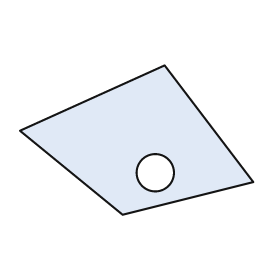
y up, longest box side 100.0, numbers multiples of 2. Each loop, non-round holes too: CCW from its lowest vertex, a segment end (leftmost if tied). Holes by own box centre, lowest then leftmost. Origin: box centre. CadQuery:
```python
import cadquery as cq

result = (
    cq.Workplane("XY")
    .moveTo(-6.0, -32.0)
    .lineTo(50.0, -18.0)
    .lineTo(12.0, 32.0)
    .lineTo(-50.0, 4.0)
    .close()
    .moveTo(8.0, -14.0)
    .circle(8.0)
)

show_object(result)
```